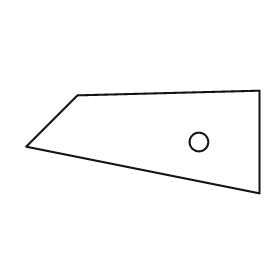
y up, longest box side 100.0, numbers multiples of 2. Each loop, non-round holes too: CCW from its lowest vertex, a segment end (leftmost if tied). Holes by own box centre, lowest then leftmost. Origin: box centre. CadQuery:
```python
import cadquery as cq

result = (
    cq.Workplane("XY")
    .moveTo(50.0, -22.0)
    .lineTo(50.0, 22.0)
    .lineTo(-28.0, 20.0)
    .lineTo(-50.0, -2.0)
    .close()
    .moveTo(24.0, 0.0)
    .circle(4.0)
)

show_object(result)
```